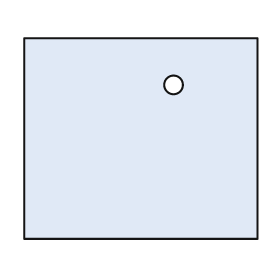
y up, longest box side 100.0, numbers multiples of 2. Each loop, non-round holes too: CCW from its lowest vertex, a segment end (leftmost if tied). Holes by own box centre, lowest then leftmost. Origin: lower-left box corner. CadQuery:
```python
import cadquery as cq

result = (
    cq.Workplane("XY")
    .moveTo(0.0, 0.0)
    .lineTo(100.0, 0.0)
    .lineTo(100.0, 86.0)
    .lineTo(0.0, 86.0)
    .close()
    .moveTo(64.0, 66.0)
    .circle(4.0)
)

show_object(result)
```